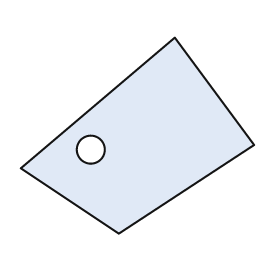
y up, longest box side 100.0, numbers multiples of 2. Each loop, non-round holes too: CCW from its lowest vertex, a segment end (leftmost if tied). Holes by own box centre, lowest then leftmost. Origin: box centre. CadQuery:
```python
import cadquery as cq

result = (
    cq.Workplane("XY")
    .moveTo(-8.0, -42.0)
    .lineTo(50.0, -4.0)
    .lineTo(16.0, 42.0)
    .lineTo(-50.0, -14.0)
    .close()
    .moveTo(-20.0, -6.0)
    .circle(6.0)
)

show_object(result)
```